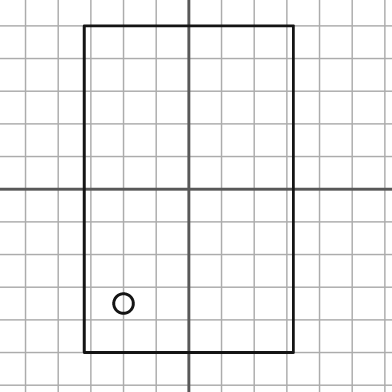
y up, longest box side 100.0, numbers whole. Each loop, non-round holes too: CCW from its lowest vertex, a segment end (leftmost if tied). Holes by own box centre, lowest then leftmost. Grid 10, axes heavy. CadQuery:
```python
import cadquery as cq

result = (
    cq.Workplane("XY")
    .moveTo(-32.0, -50.0)
    .lineTo(32.0, -50.0)
    .lineTo(32.0, 50.0)
    .lineTo(-32.0, 50.0)
    .close()
    .moveTo(-20.0, -35.0)
    .circle(3.0)
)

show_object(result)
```